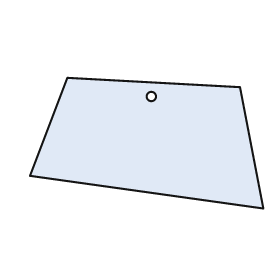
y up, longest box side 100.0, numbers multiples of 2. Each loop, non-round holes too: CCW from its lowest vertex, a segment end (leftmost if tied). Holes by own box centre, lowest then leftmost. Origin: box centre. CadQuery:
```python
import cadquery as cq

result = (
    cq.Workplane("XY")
    .moveTo(50.0, -28.0)
    .lineTo(40.0, 24.0)
    .lineTo(-34.0, 28.0)
    .lineTo(-50.0, -14.0)
    .close()
    .moveTo(2.0, 20.0)
    .circle(2.0)
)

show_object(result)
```